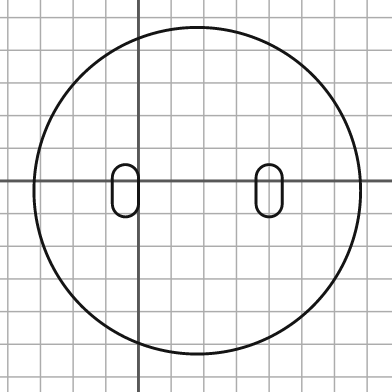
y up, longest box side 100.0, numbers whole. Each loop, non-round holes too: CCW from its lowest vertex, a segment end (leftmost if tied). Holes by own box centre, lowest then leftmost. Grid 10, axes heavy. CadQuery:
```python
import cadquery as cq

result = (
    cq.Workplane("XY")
    .moveTo(18.0, -3.0)
    .circle(50.0)
    .moveTo(-8.0, -7.0)
    .threePointArc((-4.0, -11.0), (0.0, -7.0))
    .lineTo(0.0, 1.0)
    .threePointArc((-4.0, 5.0), (-8.0, 1.0))
    .close()
    .moveTo(36.0, -7.0)
    .threePointArc((40.0, -11.0), (44.0, -7.0))
    .lineTo(44.0, 1.0)
    .threePointArc((40.0, 5.0), (36.0, 1.0))
    .close()
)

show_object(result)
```